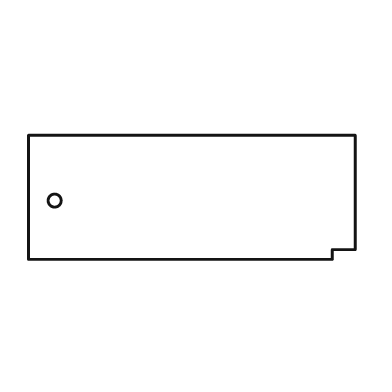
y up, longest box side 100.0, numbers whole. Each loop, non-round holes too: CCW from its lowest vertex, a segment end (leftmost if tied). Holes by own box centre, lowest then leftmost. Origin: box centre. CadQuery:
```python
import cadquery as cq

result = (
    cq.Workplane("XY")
    .moveTo(-50.0, -19.0)
    .lineTo(43.0, -19.0)
    .lineTo(43.0, -16.0)
    .lineTo(50.0, -16.0)
    .lineTo(50.0, 19.0)
    .lineTo(-50.0, 19.0)
    .close()
    .moveTo(-42.0, -1.0)
    .circle(2.0)
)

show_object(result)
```